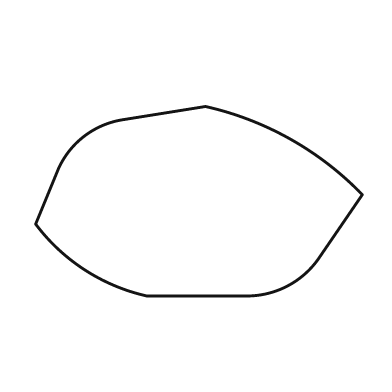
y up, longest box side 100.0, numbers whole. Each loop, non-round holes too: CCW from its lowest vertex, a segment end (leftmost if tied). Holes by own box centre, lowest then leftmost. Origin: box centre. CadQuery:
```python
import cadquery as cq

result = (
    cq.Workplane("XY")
    .moveTo(-16.0, -29.0)
    .lineTo(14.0, -29.0)
    .threePointArc((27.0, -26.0), (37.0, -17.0))
    .lineTo(50.0, 2.0)
    .threePointArc((28.0, 19.0), (2.0, 29.0))
    .lineTo(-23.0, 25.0)
    .threePointArc((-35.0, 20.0), (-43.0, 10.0))
    .lineTo(-50.0, -7.0)
    .threePointArc((-35.0, -21.0), (-16.0, -29.0))
    .close()
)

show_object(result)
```